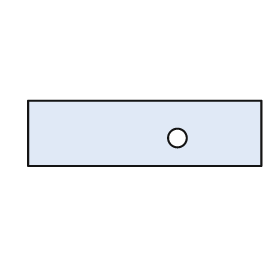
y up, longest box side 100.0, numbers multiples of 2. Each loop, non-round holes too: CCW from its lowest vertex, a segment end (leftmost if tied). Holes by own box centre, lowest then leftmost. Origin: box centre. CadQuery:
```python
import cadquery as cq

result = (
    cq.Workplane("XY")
    .moveTo(-50.0, -14.0)
    .lineTo(50.0, -14.0)
    .lineTo(50.0, 14.0)
    .lineTo(-50.0, 14.0)
    .close()
    .moveTo(14.0, -2.0)
    .circle(4.0)
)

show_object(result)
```